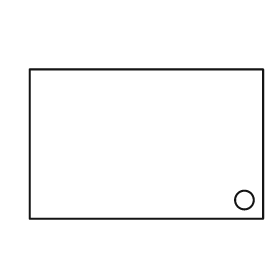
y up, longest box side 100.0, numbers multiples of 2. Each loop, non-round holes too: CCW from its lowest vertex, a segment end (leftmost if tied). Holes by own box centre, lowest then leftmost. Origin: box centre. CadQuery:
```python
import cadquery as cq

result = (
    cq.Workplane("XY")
    .moveTo(-50.0, -32.0)
    .lineTo(50.0, -32.0)
    .lineTo(50.0, 32.0)
    .lineTo(-50.0, 32.0)
    .close()
    .moveTo(42.0, -24.0)
    .circle(4.0)
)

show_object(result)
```